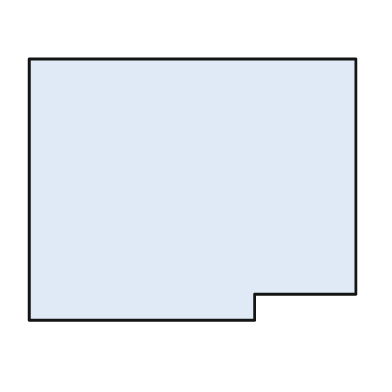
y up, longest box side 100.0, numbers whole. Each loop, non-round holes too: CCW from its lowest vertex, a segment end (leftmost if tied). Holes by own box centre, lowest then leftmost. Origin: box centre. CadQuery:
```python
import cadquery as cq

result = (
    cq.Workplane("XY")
    .moveTo(-50.0, -40.0)
    .lineTo(19.0, -40.0)
    .lineTo(19.0, -32.0)
    .lineTo(50.0, -32.0)
    .lineTo(50.0, 40.0)
    .lineTo(-50.0, 40.0)
    .close()
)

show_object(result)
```